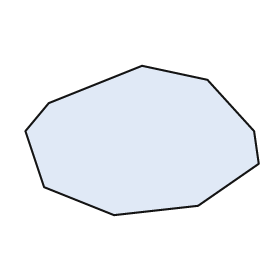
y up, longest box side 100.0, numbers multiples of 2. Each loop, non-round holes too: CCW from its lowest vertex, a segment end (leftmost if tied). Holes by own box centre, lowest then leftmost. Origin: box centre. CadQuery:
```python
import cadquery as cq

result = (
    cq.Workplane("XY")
    .moveTo(-12.0, -32.0)
    .lineTo(24.0, -28.0)
    .lineTo(50.0, -10.0)
    .lineTo(48.0, 4.0)
    .lineTo(28.0, 26.0)
    .lineTo(0.0, 32.0)
    .lineTo(-40.0, 16.0)
    .lineTo(-50.0, 4.0)
    .lineTo(-42.0, -20.0)
    .close()
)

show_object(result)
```